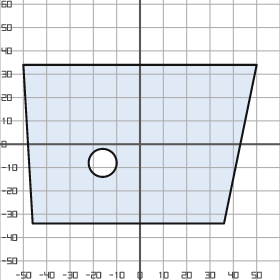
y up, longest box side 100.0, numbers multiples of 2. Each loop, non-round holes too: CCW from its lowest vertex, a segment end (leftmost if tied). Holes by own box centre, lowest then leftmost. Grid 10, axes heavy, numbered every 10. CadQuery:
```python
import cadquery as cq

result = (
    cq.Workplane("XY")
    .moveTo(-46.0, -34.0)
    .lineTo(36.0, -34.0)
    .lineTo(50.0, 34.0)
    .lineTo(-50.0, 34.0)
    .close()
    .moveTo(-16.0, -8.0)
    .circle(6.0)
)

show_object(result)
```